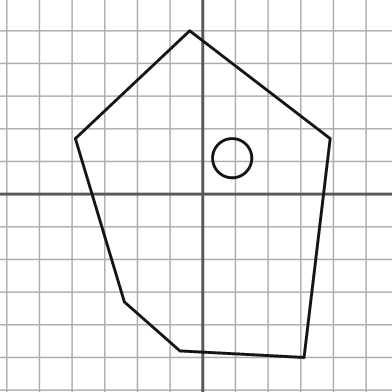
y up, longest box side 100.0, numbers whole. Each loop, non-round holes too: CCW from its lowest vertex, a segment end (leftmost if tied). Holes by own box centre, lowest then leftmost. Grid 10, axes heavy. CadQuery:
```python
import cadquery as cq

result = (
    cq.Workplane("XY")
    .moveTo(31.0, -50.0)
    .lineTo(39.0, 17.0)
    .lineTo(-4.0, 50.0)
    .lineTo(-39.0, 17.0)
    .lineTo(-24.0, -33.0)
    .lineTo(-7.0, -48.0)
    .close()
    .moveTo(9.0, 11.0)
    .circle(6.0)
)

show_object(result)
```